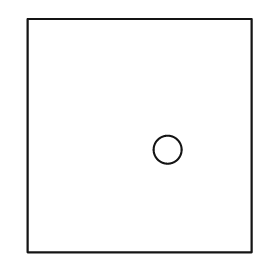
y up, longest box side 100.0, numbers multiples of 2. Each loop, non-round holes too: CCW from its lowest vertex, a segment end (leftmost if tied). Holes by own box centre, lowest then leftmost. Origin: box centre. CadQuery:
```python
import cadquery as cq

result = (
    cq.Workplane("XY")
    .moveTo(-48.0, -50.0)
    .lineTo(48.0, -50.0)
    .lineTo(48.0, 50.0)
    .lineTo(-48.0, 50.0)
    .close()
    .moveTo(12.0, -6.0)
    .circle(6.0)
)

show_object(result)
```